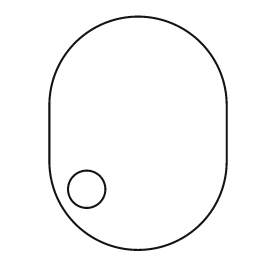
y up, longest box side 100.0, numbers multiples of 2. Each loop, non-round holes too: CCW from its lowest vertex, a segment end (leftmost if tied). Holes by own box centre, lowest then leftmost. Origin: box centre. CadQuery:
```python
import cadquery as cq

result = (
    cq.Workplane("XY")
    .moveTo(-38.0, -12.0)
    .threePointArc((0.0, -50.0), (38.0, -12.0))
    .lineTo(38.0, 12.0)
    .threePointArc((0.0, 50.0), (-38.0, 12.0))
    .close()
    .moveTo(-22.0, -24.0)
    .circle(8.0)
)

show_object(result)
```